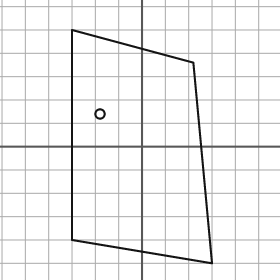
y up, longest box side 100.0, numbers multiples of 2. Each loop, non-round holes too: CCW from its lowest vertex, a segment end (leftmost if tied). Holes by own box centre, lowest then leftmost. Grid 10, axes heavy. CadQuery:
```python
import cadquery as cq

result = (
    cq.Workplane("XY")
    .moveTo(30.0, -50.0)
    .lineTo(22.0, 36.0)
    .lineTo(-30.0, 50.0)
    .lineTo(-30.0, -40.0)
    .close()
    .moveTo(-18.0, 14.0)
    .circle(2.0)
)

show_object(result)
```